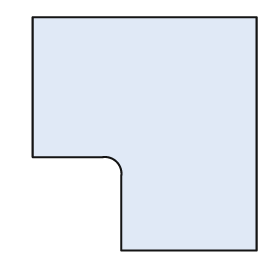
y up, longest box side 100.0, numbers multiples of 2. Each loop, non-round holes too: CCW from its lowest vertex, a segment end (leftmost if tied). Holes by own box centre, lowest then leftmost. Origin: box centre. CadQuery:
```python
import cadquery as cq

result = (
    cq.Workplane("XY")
    .moveTo(-10.0, -50.0)
    .lineTo(48.0, -50.0)
    .lineTo(48.0, 50.0)
    .lineTo(-48.0, 50.0)
    .lineTo(-48.0, -10.0)
    .lineTo(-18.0, -10.0)
    .threePointArc((-12.0, -12.0), (-10.0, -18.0))
    .close()
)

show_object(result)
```